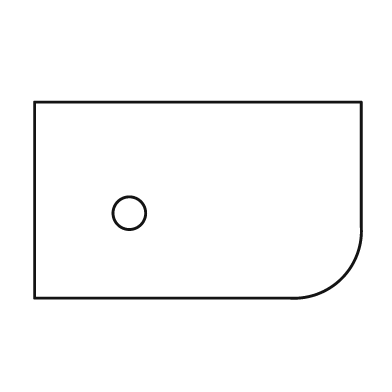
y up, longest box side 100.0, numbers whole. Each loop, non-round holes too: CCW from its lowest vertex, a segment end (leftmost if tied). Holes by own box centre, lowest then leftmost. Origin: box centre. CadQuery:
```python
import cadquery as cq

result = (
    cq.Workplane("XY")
    .moveTo(-50.0, -30.0)
    .lineTo(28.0, -30.0)
    .threePointArc((44.0, -24.0), (50.0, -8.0))
    .lineTo(50.0, 30.0)
    .lineTo(-50.0, 30.0)
    .close()
    .moveTo(-21.0, -4.0)
    .circle(5.0)
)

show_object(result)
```